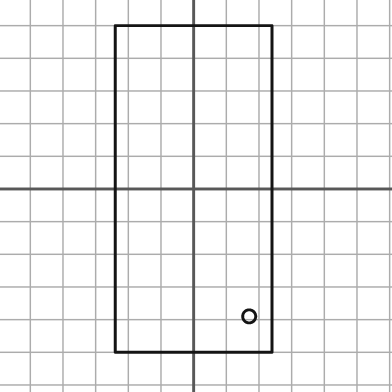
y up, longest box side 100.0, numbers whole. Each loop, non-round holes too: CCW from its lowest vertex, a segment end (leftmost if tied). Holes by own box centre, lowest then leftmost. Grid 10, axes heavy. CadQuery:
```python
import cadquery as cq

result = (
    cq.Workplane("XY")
    .moveTo(-24.0, -50.0)
    .lineTo(24.0, -50.0)
    .lineTo(24.0, 50.0)
    .lineTo(-24.0, 50.0)
    .close()
    .moveTo(17.0, -39.0)
    .circle(2.0)
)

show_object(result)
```